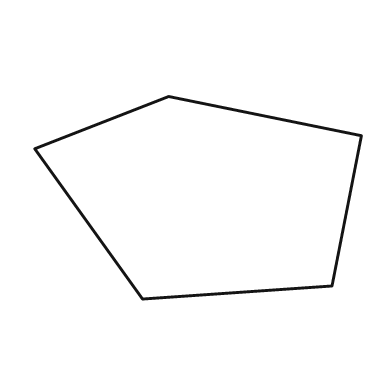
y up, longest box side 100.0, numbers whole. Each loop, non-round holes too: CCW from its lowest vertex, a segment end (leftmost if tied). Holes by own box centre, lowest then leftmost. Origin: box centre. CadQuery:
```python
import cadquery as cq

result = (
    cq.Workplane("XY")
    .moveTo(-17.0, -31.0)
    .lineTo(41.0, -27.0)
    .lineTo(50.0, 19.0)
    .lineTo(-9.0, 31.0)
    .lineTo(-50.0, 15.0)
    .close()
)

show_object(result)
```